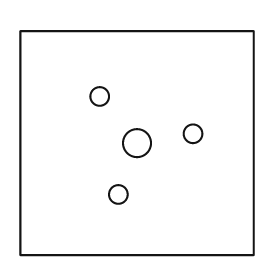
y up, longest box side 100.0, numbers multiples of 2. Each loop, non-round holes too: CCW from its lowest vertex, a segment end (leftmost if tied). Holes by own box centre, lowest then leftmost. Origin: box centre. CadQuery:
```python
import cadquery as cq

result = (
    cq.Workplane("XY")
    .moveTo(-50.0, -48.0)
    .lineTo(50.0, -48.0)
    .lineTo(50.0, 48.0)
    .lineTo(-50.0, 48.0)
    .close()
    .moveTo(-8.0, -22.0)
    .circle(4.0)
    .moveTo(0.0, 0.0)
    .circle(6.0)
    .moveTo(24.0, 4.0)
    .circle(4.0)
    .moveTo(-16.0, 20.0)
    .circle(4.0)
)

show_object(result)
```